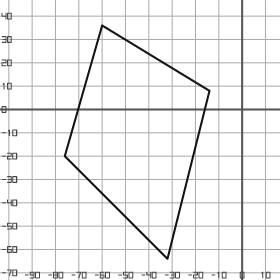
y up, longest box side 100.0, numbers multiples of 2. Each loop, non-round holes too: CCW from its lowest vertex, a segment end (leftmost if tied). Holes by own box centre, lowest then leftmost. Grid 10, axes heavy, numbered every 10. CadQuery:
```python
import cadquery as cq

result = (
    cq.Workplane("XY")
    .moveTo(-32.0, -64.0)
    .lineTo(-14.0, 8.0)
    .lineTo(-60.0, 36.0)
    .lineTo(-76.0, -20.0)
    .close()
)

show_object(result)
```